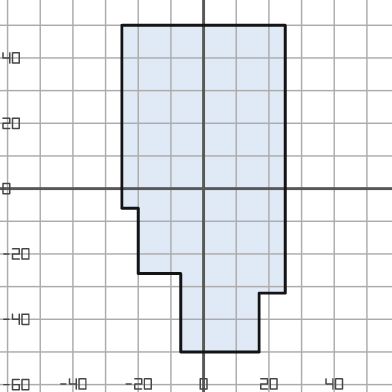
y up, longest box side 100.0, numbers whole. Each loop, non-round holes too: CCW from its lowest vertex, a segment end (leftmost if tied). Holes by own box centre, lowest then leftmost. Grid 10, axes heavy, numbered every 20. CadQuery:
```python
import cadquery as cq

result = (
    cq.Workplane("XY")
    .moveTo(-7.0, -50.0)
    .lineTo(17.0, -50.0)
    .lineTo(17.0, -32.0)
    .lineTo(25.0, -32.0)
    .lineTo(25.0, 50.0)
    .lineTo(-25.0, 50.0)
    .lineTo(-25.0, -6.0)
    .lineTo(-20.0, -6.0)
    .lineTo(-20.0, -26.0)
    .lineTo(-7.0, -26.0)
    .close()
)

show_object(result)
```